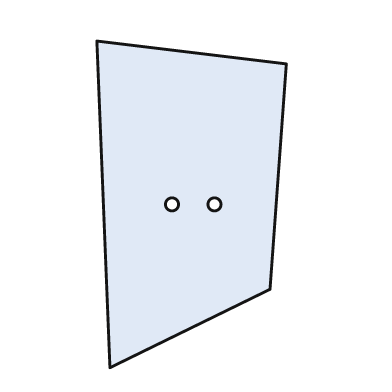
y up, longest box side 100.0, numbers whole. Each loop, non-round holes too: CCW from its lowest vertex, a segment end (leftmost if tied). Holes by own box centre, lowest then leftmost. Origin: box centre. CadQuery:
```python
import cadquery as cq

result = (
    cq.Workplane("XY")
    .moveTo(-25.0, -50.0)
    .lineTo(24.0, -26.0)
    .lineTo(29.0, 43.0)
    .lineTo(-29.0, 50.0)
    .close()
    .moveTo(-6.0, 0.0)
    .circle(2.0)
    .moveTo(7.0, 0.0)
    .circle(2.0)
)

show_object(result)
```